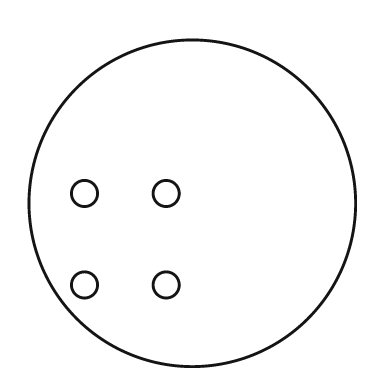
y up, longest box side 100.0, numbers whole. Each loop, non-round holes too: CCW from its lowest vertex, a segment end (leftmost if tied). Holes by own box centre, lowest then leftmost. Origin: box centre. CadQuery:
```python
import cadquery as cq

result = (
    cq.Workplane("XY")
    .moveTo(0.0, 0.0)
    .circle(50.0)
    .moveTo(-33.0, -25.0)
    .circle(4.0)
    .moveTo(-8.0, -25.0)
    .circle(4.0)
    .moveTo(-33.0, 3.0)
    .circle(4.0)
    .moveTo(-8.0, 3.0)
    .circle(4.0)
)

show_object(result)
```